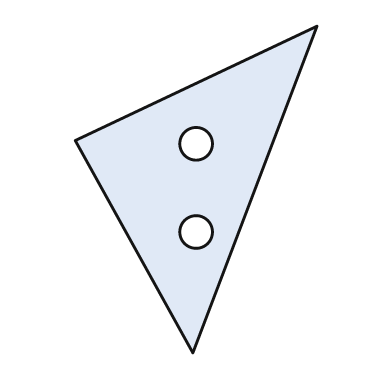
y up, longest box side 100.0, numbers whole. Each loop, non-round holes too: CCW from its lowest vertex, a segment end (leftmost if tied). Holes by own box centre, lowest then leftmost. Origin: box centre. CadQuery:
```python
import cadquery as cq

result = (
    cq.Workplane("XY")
    .moveTo(-1.0, -50.0)
    .lineTo(37.0, 50.0)
    .lineTo(-37.0, 15.0)
    .close()
    .moveTo(0.0, -13.0)
    .circle(5.0)
    .moveTo(0.0, 14.0)
    .circle(5.0)
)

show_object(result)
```